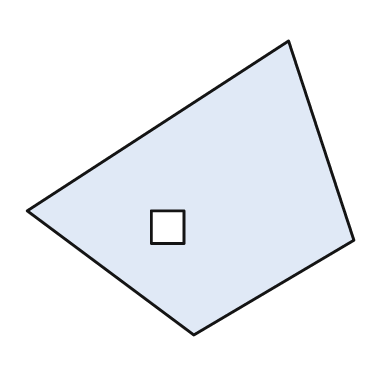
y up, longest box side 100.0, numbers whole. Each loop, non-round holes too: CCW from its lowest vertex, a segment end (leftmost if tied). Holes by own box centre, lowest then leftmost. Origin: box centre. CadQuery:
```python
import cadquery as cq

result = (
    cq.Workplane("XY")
    .moveTo(1.0, -45.0)
    .lineTo(50.0, -16.0)
    .lineTo(30.0, 45.0)
    .lineTo(-50.0, -7.0)
    .close()
    .moveTo(-12.0, -17.0)
    .lineTo(-2.0, -17.0)
    .lineTo(-2.0, -7.0)
    .lineTo(-12.0, -7.0)
    .close()
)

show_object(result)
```